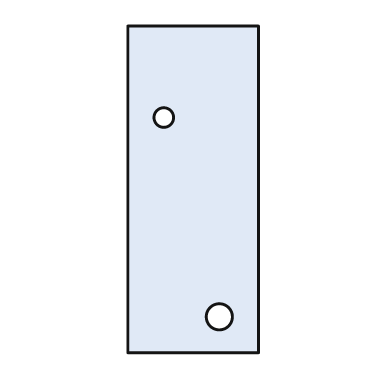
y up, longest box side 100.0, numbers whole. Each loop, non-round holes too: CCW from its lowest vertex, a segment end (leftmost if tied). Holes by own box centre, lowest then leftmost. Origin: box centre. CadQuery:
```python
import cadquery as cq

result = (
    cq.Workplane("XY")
    .moveTo(-20.0, -50.0)
    .lineTo(20.0, -50.0)
    .lineTo(20.0, 50.0)
    .lineTo(-20.0, 50.0)
    .close()
    .moveTo(8.0, -39.0)
    .circle(4.0)
    .moveTo(-9.0, 22.0)
    .circle(3.0)
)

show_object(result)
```